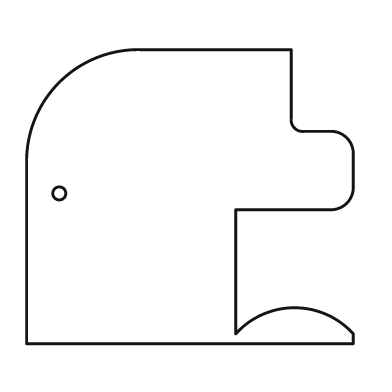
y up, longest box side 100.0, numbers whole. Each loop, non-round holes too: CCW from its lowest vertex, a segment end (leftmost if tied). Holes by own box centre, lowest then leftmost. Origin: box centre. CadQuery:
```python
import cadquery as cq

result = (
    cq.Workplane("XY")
    .moveTo(-50.0, -45.0)
    .lineTo(50.0, -45.0)
    .lineTo(50.0, -42.0)
    .threePointArc((32.0, -34.0), (14.0, -42.0))
    .lineTo(14.0, -4.0)
    .lineTo(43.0, -4.0)
    .threePointArc((48.0, -2.0), (50.0, 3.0))
    .lineTo(50.0, 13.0)
    .threePointArc((48.0, 18.0), (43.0, 20.0))
    .lineTo(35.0, 20.0)
    .threePointArc((32.0, 21.0), (31.0, 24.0))
    .lineTo(31.0, 45.0)
    .lineTo(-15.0, 45.0)
    .threePointArc((-40.0, 35.0), (-50.0, 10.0))
    .close()
    .moveTo(-40.0, 1.0)
    .circle(2.0)
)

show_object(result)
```